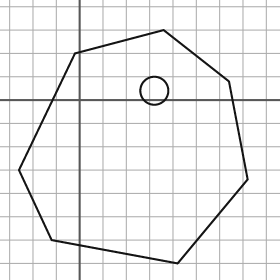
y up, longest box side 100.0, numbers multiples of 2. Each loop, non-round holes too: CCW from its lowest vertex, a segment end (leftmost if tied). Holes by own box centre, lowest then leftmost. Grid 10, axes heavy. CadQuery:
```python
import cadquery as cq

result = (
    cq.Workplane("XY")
    .moveTo(42.0, -70.0)
    .lineTo(72.0, -34.0)
    .lineTo(64.0, 8.0)
    .lineTo(36.0, 30.0)
    .lineTo(-2.0, 20.0)
    .lineTo(-26.0, -30.0)
    .lineTo(-12.0, -60.0)
    .close()
    .moveTo(32.0, 4.0)
    .circle(6.0)
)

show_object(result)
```